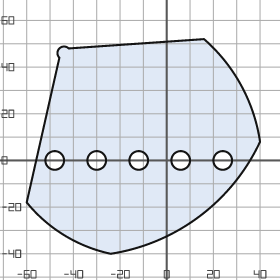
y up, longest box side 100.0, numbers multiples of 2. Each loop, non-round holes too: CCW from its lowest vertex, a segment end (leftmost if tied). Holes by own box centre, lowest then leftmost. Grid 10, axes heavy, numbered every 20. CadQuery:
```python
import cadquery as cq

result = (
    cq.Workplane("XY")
    .moveTo(-24.0, -40.0)
    .threePointArc((14.0, -24.0), (40.0, 8.0))
    .threePointArc((32.0, 32.0), (16.0, 52.0))
    .lineTo(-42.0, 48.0)
    .threePointArc((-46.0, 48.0), (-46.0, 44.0))
    .lineTo(-60.0, -18.0)
    .threePointArc((-44.0, -32.0), (-24.0, -40.0))
    .close()
    .moveTo(-48.0, 0.0)
    .circle(4.0)
    .moveTo(-30.0, 0.0)
    .circle(4.0)
    .moveTo(-12.0, 0.0)
    .circle(4.0)
    .moveTo(6.0, 0.0)
    .circle(4.0)
    .moveTo(24.0, 0.0)
    .circle(4.0)
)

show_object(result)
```